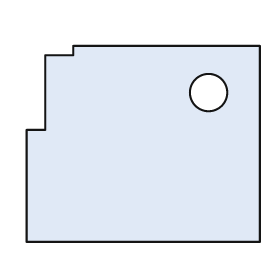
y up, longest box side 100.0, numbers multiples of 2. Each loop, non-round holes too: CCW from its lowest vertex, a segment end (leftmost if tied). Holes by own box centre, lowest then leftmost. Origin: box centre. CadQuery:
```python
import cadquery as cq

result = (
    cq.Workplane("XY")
    .moveTo(-50.0, -42.0)
    .lineTo(50.0, -42.0)
    .lineTo(50.0, 42.0)
    .lineTo(-30.0, 42.0)
    .lineTo(-30.0, 38.0)
    .lineTo(-42.0, 38.0)
    .lineTo(-42.0, 6.0)
    .lineTo(-50.0, 6.0)
    .close()
    .moveTo(28.0, 22.0)
    .circle(8.0)
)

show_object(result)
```